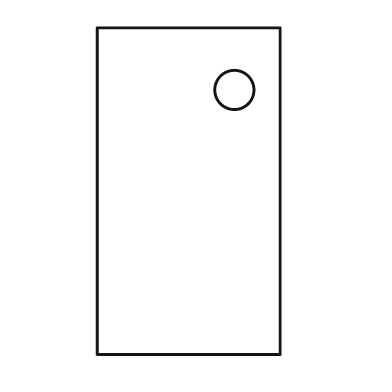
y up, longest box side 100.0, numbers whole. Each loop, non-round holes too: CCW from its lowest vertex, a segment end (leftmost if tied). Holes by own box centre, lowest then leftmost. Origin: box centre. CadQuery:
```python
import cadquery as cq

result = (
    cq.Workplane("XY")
    .moveTo(-28.0, -50.0)
    .lineTo(28.0, -50.0)
    .lineTo(28.0, 50.0)
    .lineTo(-28.0, 50.0)
    .close()
    .moveTo(14.0, 31.0)
    .circle(6.0)
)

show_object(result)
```